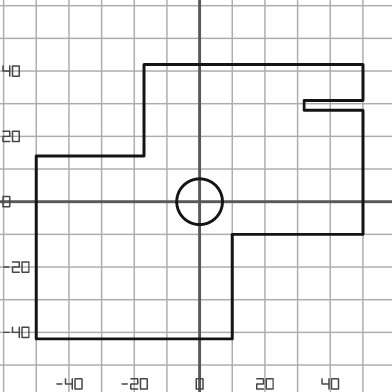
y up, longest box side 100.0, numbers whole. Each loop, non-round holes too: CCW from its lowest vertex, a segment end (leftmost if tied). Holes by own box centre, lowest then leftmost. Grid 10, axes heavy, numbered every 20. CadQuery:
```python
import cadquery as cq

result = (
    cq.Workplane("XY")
    .moveTo(-50.0, -42.0)
    .lineTo(10.0, -42.0)
    .lineTo(10.0, -10.0)
    .lineTo(50.0, -10.0)
    .lineTo(50.0, 28.0)
    .lineTo(32.0, 28.0)
    .lineTo(32.0, 31.0)
    .lineTo(50.0, 31.0)
    .lineTo(50.0, 42.0)
    .lineTo(-17.0, 42.0)
    .lineTo(-17.0, 14.0)
    .lineTo(-50.0, 14.0)
    .close()
    .moveTo(0.0, 0.0)
    .circle(7.0)
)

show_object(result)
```